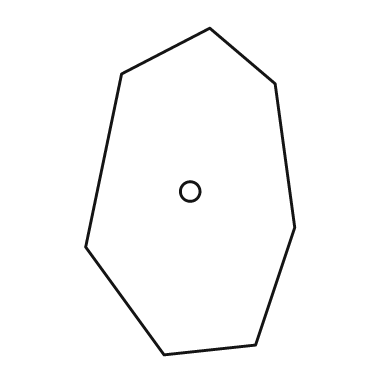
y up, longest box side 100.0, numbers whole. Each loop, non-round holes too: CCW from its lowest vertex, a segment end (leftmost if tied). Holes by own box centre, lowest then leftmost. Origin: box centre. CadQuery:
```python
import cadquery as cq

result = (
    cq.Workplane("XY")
    .moveTo(-8.0, -50.0)
    .lineTo(20.0, -47.0)
    .lineTo(32.0, -11.0)
    .lineTo(26.0, 33.0)
    .lineTo(6.0, 50.0)
    .lineTo(-21.0, 36.0)
    .lineTo(-32.0, -17.0)
    .close()
    .moveTo(0.0, 0.0)
    .circle(3.0)
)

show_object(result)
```